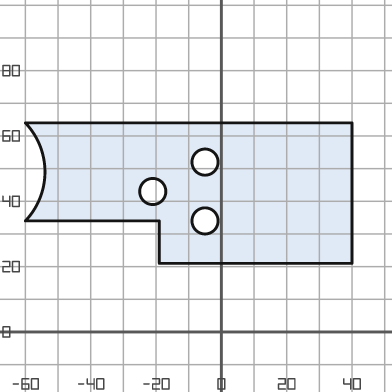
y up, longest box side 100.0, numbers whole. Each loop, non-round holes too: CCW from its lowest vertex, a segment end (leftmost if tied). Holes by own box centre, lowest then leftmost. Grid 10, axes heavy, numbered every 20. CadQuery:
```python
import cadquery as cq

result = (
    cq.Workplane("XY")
    .moveTo(-19.0, 21.0)
    .lineTo(40.0, 21.0)
    .lineTo(40.0, 64.0)
    .lineTo(-60.0, 64.0)
    .threePointArc((-54.0, 49.0), (-60.0, 34.0))
    .lineTo(-19.0, 34.0)
    .close()
    .moveTo(-5.0, 34.0)
    .circle(4.0)
    .moveTo(-21.0, 43.0)
    .circle(4.0)
    .moveTo(-5.0, 52.0)
    .circle(4.0)
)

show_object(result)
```